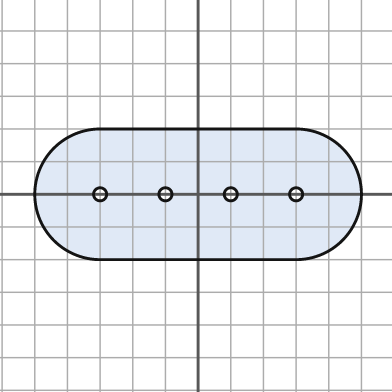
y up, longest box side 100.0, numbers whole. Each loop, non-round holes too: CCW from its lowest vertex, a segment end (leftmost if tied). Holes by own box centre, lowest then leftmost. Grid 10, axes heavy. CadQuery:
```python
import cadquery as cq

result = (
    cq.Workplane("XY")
    .moveTo(-30.0, -20.0)
    .lineTo(30.0, -20.0)
    .threePointArc((50.0, 0.0), (30.0, 20.0))
    .lineTo(-30.0, 20.0)
    .threePointArc((-50.0, 0.0), (-30.0, -20.0))
    .close()
    .moveTo(-30.0, 0.0)
    .circle(2.0)
    .moveTo(-10.0, 0.0)
    .circle(2.0)
    .moveTo(10.0, 0.0)
    .circle(2.0)
    .moveTo(30.0, 0.0)
    .circle(2.0)
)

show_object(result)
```